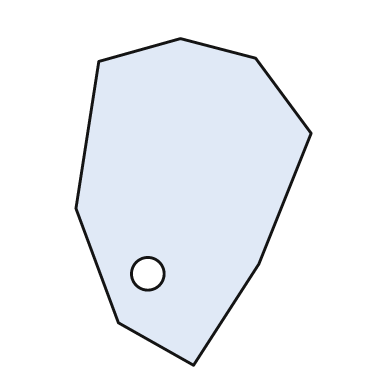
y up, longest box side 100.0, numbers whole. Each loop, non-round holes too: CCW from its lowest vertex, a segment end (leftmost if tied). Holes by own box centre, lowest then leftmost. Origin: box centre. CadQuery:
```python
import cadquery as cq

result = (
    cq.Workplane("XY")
    .moveTo(0.0, -50.0)
    .lineTo(20.0, -19.0)
    .lineTo(36.0, 21.0)
    .lineTo(19.0, 44.0)
    .lineTo(-4.0, 50.0)
    .lineTo(-29.0, 43.0)
    .lineTo(-36.0, -2.0)
    .lineTo(-23.0, -37.0)
    .close()
    .moveTo(-14.0, -22.0)
    .circle(5.0)
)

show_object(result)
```